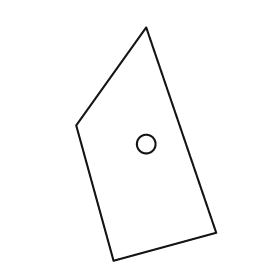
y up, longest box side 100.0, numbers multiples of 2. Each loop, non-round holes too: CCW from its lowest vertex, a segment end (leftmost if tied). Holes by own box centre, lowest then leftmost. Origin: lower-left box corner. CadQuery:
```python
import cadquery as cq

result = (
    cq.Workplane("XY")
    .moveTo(16.0, 0.0)
    .lineTo(60.0, 12.0)
    .lineTo(30.0, 100.0)
    .lineTo(0.0, 58.0)
    .close()
    .moveTo(30.0, 50.0)
    .circle(4.0)
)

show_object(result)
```